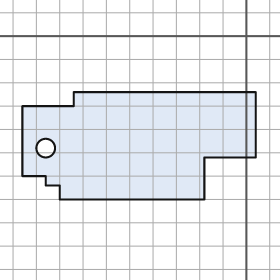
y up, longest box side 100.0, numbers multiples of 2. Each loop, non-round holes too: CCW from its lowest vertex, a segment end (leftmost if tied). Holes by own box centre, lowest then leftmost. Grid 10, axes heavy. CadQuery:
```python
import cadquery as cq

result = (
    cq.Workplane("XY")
    .moveTo(-80.0, -70.0)
    .lineTo(-18.0, -70.0)
    .lineTo(-18.0, -52.0)
    .lineTo(4.0, -52.0)
    .lineTo(4.0, -24.0)
    .lineTo(-74.0, -24.0)
    .lineTo(-74.0, -30.0)
    .lineTo(-96.0, -30.0)
    .lineTo(-96.0, -60.0)
    .lineTo(-86.0, -60.0)
    .lineTo(-86.0, -64.0)
    .lineTo(-80.0, -64.0)
    .close()
    .moveTo(-86.0, -48.0)
    .circle(4.0)
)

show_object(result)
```